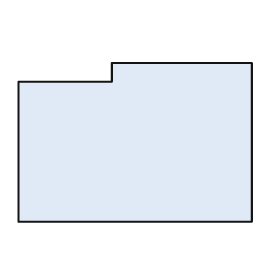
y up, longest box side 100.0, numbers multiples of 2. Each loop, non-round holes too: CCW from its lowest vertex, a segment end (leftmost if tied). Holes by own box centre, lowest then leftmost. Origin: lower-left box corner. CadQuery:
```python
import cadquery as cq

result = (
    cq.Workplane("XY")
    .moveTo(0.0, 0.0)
    .lineTo(100.0, 0.0)
    .lineTo(100.0, 68.0)
    .lineTo(40.0, 68.0)
    .lineTo(40.0, 60.0)
    .lineTo(0.0, 60.0)
    .close()
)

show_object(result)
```